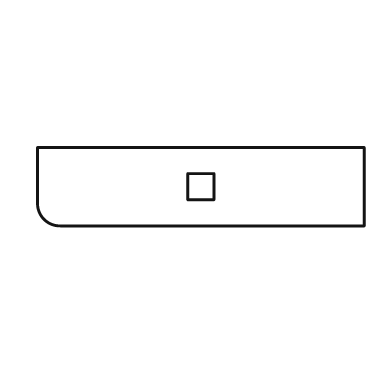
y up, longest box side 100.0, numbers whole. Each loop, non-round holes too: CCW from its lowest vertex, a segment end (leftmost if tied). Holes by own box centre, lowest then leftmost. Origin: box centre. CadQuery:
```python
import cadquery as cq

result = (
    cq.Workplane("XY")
    .moveTo(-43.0, -12.0)
    .lineTo(50.0, -12.0)
    .lineTo(50.0, 12.0)
    .lineTo(-50.0, 12.0)
    .lineTo(-50.0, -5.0)
    .threePointArc((-48.0, -10.0), (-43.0, -12.0))
    .close()
    .moveTo(-4.0, -4.0)
    .lineTo(4.0, -4.0)
    .lineTo(4.0, 4.0)
    .lineTo(-4.0, 4.0)
    .close()
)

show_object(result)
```